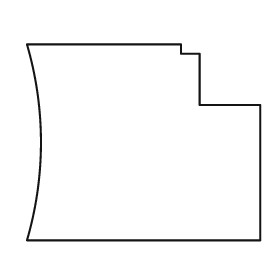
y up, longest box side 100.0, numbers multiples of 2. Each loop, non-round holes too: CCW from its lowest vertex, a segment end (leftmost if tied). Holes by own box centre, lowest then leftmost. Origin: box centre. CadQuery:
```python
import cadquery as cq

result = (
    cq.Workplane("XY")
    .moveTo(-50.0, -42.0)
    .lineTo(50.0, -42.0)
    .lineTo(50.0, 16.0)
    .lineTo(24.0, 16.0)
    .lineTo(24.0, 38.0)
    .lineTo(16.0, 38.0)
    .lineTo(16.0, 42.0)
    .lineTo(-50.0, 42.0)
    .threePointArc((-44.0, 0.0), (-50.0, -42.0))
    .close()
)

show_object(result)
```